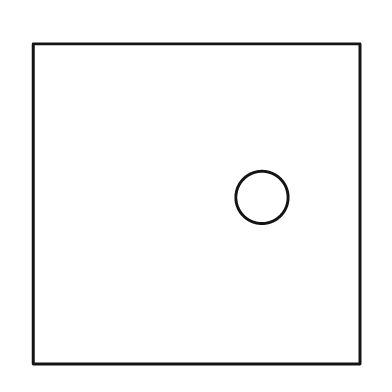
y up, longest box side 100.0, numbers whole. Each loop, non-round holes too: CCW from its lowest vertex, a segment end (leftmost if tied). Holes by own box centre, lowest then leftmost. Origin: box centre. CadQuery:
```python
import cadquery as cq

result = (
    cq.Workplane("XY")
    .moveTo(-50.0, -49.0)
    .lineTo(50.0, -49.0)
    .lineTo(50.0, 49.0)
    .lineTo(-50.0, 49.0)
    .close()
    .moveTo(20.0, 2.0)
    .circle(8.0)
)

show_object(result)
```